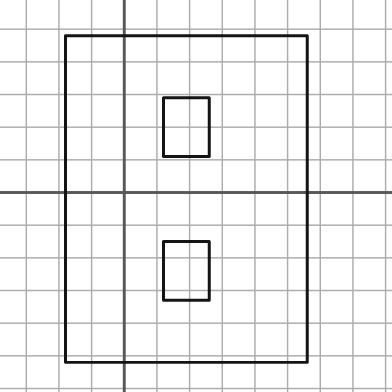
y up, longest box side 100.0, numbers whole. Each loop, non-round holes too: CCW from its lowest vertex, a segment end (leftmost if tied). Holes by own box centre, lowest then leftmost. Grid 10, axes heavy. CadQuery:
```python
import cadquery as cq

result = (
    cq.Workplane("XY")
    .moveTo(-18.0, -52.0)
    .lineTo(56.0, -52.0)
    .lineTo(56.0, 48.0)
    .lineTo(-18.0, 48.0)
    .close()
    .moveTo(12.0, -33.0)
    .lineTo(26.0, -33.0)
    .lineTo(26.0, -15.0)
    .lineTo(12.0, -15.0)
    .close()
    .moveTo(12.0, 11.0)
    .lineTo(26.0, 11.0)
    .lineTo(26.0, 29.0)
    .lineTo(12.0, 29.0)
    .close()
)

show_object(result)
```